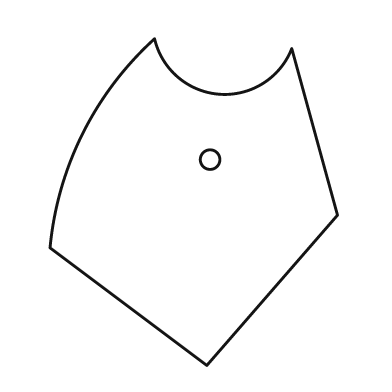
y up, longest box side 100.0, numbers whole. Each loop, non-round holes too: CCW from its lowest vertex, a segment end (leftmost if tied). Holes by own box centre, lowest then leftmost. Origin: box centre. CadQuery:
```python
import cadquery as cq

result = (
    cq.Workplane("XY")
    .moveTo(4.0, -50.0)
    .lineTo(44.0, -4.0)
    .lineTo(30.0, 47.0)
    .threePointArc((8.0, 33.0), (-12.0, 50.0))
    .threePointArc((-34.0, 21.0), (-44.0, -14.0))
    .close()
    .moveTo(5.0, 13.0)
    .circle(3.0)
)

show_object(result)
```